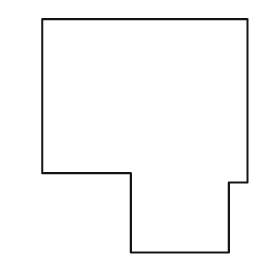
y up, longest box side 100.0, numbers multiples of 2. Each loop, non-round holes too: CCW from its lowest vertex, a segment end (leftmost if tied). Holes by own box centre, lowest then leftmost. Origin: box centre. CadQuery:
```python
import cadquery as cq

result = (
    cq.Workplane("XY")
    .moveTo(-6.0, -50.0)
    .lineTo(36.0, -50.0)
    .lineTo(36.0, -20.0)
    .lineTo(44.0, -20.0)
    .lineTo(44.0, 50.0)
    .lineTo(-44.0, 50.0)
    .lineTo(-44.0, -16.0)
    .lineTo(-6.0, -16.0)
    .close()
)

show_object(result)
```